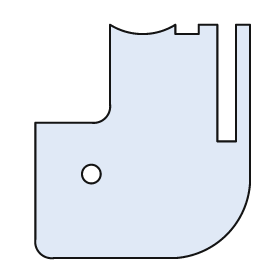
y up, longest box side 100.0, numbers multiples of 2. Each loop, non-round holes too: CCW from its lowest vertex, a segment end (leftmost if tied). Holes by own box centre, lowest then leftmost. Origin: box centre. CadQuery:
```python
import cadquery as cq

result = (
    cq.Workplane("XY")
    .moveTo(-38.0, -50.0)
    .lineTo(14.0, -50.0)
    .threePointArc((36.0, -40.0), (46.0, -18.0))
    .lineTo(46.0, 50.0)
    .lineTo(40.0, 50.0)
    .lineTo(40.0, 0.0)
    .lineTo(32.0, 0.0)
    .lineTo(32.0, 50.0)
    .lineTo(24.0, 50.0)
    .lineTo(24.0, 46.0)
    .lineTo(14.0, 46.0)
    .lineTo(14.0, 50.0)
    .threePointArc((0.0, 46.0), (-14.0, 50.0))
    .lineTo(-14.0, 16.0)
    .threePointArc((-16.0, 10.0), (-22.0, 8.0))
    .lineTo(-46.0, 8.0)
    .lineTo(-46.0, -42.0)
    .threePointArc((-44.0, -48.0), (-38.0, -50.0))
    .close()
    .moveTo(-22.0, -14.0)
    .circle(4.0)
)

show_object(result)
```